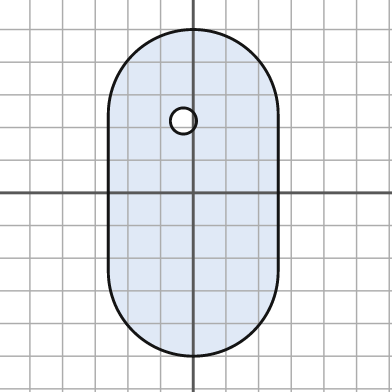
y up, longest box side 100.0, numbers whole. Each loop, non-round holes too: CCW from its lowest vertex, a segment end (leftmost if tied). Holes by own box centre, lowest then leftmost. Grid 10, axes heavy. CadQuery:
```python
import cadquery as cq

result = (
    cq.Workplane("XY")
    .moveTo(-26.0, -24.0)
    .threePointArc((0.0, -50.0), (26.0, -24.0))
    .lineTo(26.0, 24.0)
    .threePointArc((0.0, 50.0), (-26.0, 24.0))
    .close()
    .moveTo(-3.0, 22.0)
    .circle(4.0)
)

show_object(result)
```